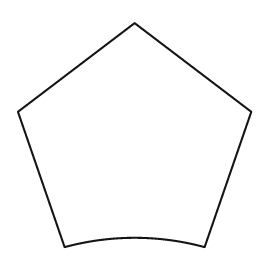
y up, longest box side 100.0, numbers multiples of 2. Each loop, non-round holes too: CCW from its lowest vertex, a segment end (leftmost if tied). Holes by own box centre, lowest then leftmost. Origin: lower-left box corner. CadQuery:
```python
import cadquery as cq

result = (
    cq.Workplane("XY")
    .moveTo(20.0, 0.0)
    .threePointArc((50.0, 4.0), (80.0, 0.0))
    .lineTo(100.0, 58.0)
    .lineTo(50.0, 96.0)
    .lineTo(0.0, 58.0)
    .close()
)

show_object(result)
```